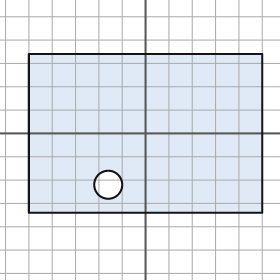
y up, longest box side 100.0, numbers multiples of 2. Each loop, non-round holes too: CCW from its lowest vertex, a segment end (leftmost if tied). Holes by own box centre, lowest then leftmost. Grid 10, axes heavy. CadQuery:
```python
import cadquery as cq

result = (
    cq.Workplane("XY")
    .moveTo(-50.0, -34.0)
    .lineTo(50.0, -34.0)
    .lineTo(50.0, 34.0)
    .lineTo(-50.0, 34.0)
    .close()
    .moveTo(-16.0, -22.0)
    .circle(6.0)
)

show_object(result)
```